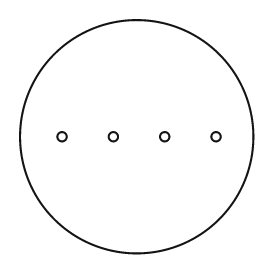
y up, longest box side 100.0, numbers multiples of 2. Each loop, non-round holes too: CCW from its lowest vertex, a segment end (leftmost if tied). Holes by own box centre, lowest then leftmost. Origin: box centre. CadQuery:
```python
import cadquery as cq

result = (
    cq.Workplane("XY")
    .moveTo(0.0, 0.0)
    .circle(50.0)
    .moveTo(-32.0, 0.0)
    .circle(2.0)
    .moveTo(-10.0, 0.0)
    .circle(2.0)
    .moveTo(12.0, 0.0)
    .circle(2.0)
    .moveTo(34.0, 0.0)
    .circle(2.0)
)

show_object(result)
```